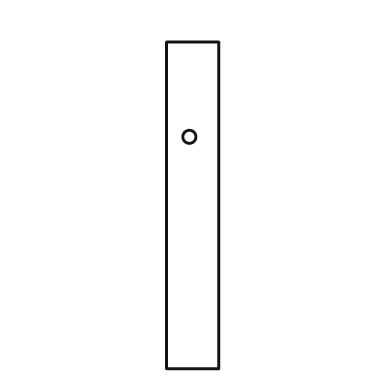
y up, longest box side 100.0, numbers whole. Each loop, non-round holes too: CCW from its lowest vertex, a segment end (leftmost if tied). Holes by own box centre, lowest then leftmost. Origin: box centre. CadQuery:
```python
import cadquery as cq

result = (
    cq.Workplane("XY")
    .moveTo(-8.0, -50.0)
    .lineTo(8.0, -50.0)
    .lineTo(8.0, 50.0)
    .lineTo(-8.0, 50.0)
    .close()
    .moveTo(-1.0, 21.0)
    .circle(2.0)
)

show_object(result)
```